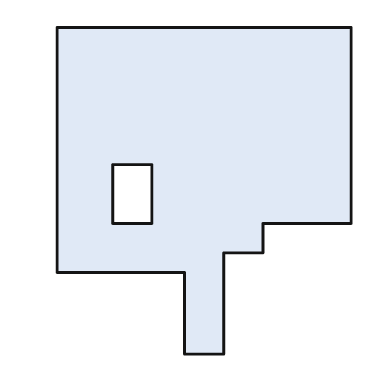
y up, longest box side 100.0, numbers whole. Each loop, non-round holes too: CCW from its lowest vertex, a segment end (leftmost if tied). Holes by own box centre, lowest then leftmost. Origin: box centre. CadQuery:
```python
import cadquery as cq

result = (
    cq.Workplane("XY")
    .moveTo(-6.0, -50.0)
    .lineTo(6.0, -50.0)
    .lineTo(6.0, -19.0)
    .lineTo(18.0, -19.0)
    .lineTo(18.0, -10.0)
    .lineTo(45.0, -10.0)
    .lineTo(45.0, 50.0)
    .lineTo(-45.0, 50.0)
    .lineTo(-45.0, -25.0)
    .lineTo(-6.0, -25.0)
    .close()
    .moveTo(-28.0, -10.0)
    .lineTo(-16.0, -10.0)
    .lineTo(-16.0, 8.0)
    .lineTo(-28.0, 8.0)
    .close()
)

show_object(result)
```